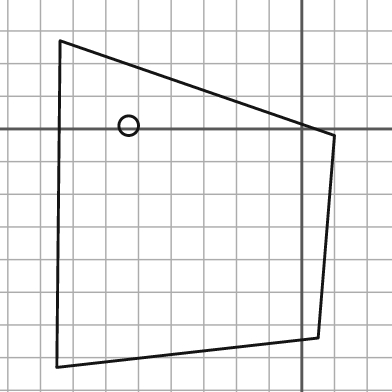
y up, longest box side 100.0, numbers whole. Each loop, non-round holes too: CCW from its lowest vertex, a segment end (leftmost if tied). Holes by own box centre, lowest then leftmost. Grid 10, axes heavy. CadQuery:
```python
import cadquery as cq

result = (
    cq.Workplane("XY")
    .moveTo(-75.0, -73.0)
    .lineTo(5.0, -64.0)
    .lineTo(10.0, -2.0)
    .lineTo(-74.0, 27.0)
    .close()
    .moveTo(-53.0, 1.0)
    .circle(3.0)
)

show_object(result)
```